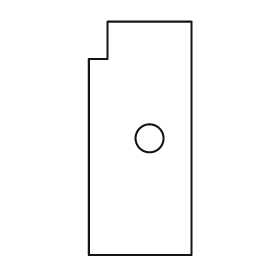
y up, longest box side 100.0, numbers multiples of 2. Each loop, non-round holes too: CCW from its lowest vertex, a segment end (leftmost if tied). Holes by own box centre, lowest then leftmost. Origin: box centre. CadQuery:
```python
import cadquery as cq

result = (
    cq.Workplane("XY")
    .moveTo(-22.0, -50.0)
    .lineTo(22.0, -50.0)
    .lineTo(22.0, 50.0)
    .lineTo(-14.0, 50.0)
    .lineTo(-14.0, 34.0)
    .lineTo(-22.0, 34.0)
    .close()
    .moveTo(4.0, 0.0)
    .circle(6.0)
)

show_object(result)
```